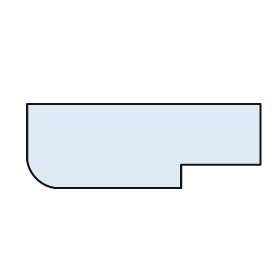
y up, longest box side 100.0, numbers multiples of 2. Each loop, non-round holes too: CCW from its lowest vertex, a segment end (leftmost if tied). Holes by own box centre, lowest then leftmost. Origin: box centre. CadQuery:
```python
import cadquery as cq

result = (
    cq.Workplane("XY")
    .moveTo(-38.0, -18.0)
    .lineTo(16.0, -18.0)
    .lineTo(16.0, -8.0)
    .lineTo(50.0, -8.0)
    .lineTo(50.0, 18.0)
    .lineTo(-50.0, 18.0)
    .lineTo(-50.0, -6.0)
    .threePointArc((-46.0, -14.0), (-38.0, -18.0))
    .close()
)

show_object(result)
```